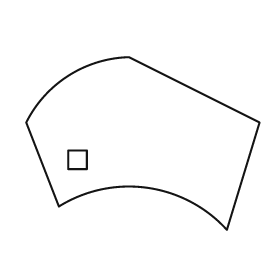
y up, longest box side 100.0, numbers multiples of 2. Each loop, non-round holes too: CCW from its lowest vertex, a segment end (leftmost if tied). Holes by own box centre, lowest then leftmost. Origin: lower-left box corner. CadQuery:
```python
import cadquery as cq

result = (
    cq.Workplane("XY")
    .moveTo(86.0, 0.0)
    .lineTo(100.0, 46.0)
    .lineTo(44.0, 74.0)
    .threePointArc((18.0, 66.0), (0.0, 46.0))
    .lineTo(14.0, 10.0)
    .threePointArc((52.0, 18.0), (86.0, 0.0))
    .close()
    .moveTo(18.0, 26.0)
    .lineTo(26.0, 26.0)
    .lineTo(26.0, 34.0)
    .lineTo(18.0, 34.0)
    .close()
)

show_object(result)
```